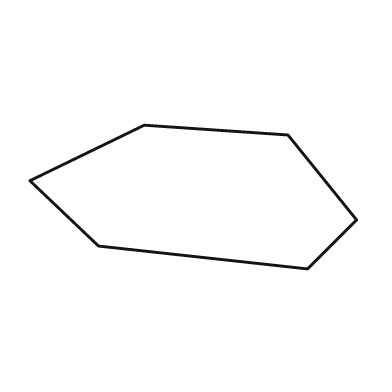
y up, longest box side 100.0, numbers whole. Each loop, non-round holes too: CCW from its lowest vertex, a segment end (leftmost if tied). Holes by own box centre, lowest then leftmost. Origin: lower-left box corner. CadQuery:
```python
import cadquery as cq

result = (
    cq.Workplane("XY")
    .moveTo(85.0, 0.0)
    .lineTo(100.0, 15.0)
    .lineTo(79.0, 41.0)
    .lineTo(35.0, 44.0)
    .lineTo(0.0, 27.0)
    .lineTo(21.0, 7.0)
    .close()
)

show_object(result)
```